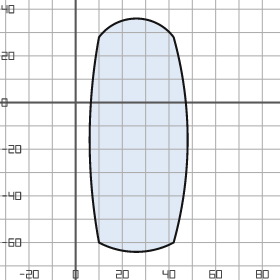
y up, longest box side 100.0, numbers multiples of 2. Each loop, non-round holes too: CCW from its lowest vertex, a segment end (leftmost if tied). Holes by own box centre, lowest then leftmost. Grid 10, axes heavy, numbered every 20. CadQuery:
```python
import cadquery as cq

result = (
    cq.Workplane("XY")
    .moveTo(10.0, -60.0)
    .threePointArc((26.0, -64.0), (42.0, -60.0))
    .threePointArc((48.0, -16.0), (42.0, 28.0))
    .threePointArc((26.0, 36.0), (10.0, 28.0))
    .threePointArc((6.0, -16.0), (10.0, -60.0))
    .close()
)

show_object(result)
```